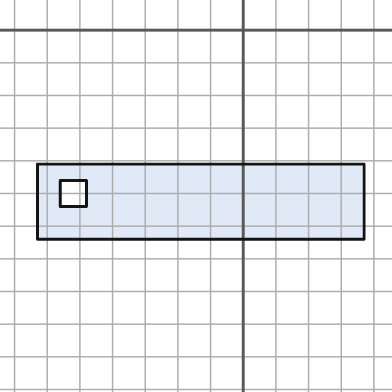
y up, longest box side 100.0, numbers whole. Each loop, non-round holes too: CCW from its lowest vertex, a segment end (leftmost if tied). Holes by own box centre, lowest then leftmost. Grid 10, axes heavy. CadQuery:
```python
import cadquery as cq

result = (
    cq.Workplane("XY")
    .moveTo(-63.0, -64.0)
    .lineTo(37.0, -64.0)
    .lineTo(37.0, -41.0)
    .lineTo(-63.0, -41.0)
    .close()
    .moveTo(-56.0, -54.0)
    .lineTo(-48.0, -54.0)
    .lineTo(-48.0, -46.0)
    .lineTo(-56.0, -46.0)
    .close()
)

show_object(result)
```